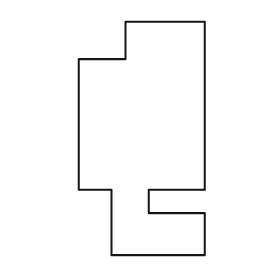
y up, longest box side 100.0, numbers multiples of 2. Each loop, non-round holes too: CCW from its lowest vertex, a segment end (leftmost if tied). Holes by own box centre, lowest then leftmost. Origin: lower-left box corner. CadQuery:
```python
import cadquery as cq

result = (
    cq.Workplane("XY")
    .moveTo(14.0, 0.0)
    .lineTo(54.0, 0.0)
    .lineTo(54.0, 18.0)
    .lineTo(30.0, 18.0)
    .lineTo(30.0, 28.0)
    .lineTo(54.0, 28.0)
    .lineTo(54.0, 100.0)
    .lineTo(20.0, 100.0)
    .lineTo(20.0, 84.0)
    .lineTo(0.0, 84.0)
    .lineTo(0.0, 28.0)
    .lineTo(14.0, 28.0)
    .close()
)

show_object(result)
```